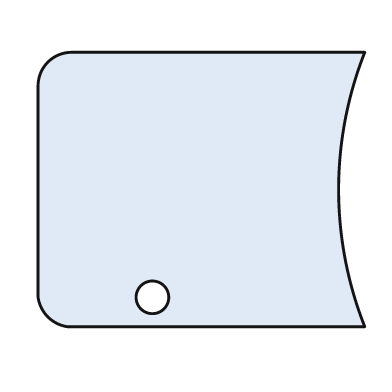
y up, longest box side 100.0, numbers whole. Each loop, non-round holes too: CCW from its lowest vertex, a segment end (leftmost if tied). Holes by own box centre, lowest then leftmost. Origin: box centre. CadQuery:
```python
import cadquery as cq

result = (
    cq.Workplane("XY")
    .moveTo(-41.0, -42.0)
    .lineTo(50.0, -42.0)
    .threePointArc((42.0, 0.0), (50.0, 42.0))
    .lineTo(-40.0, 42.0)
    .threePointArc((-47.0, 39.0), (-50.0, 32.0))
    .lineTo(-50.0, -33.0)
    .threePointArc((-47.0, -39.0), (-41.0, -42.0))
    .close()
    .moveTo(-15.0, -33.0)
    .circle(5.0)
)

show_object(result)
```